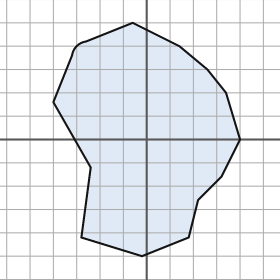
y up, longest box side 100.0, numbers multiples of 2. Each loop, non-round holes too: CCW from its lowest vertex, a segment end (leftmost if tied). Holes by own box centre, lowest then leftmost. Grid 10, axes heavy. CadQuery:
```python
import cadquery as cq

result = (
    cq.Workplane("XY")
    .moveTo(-2.0, -50.0)
    .lineTo(18.0, -42.0)
    .lineTo(22.0, -26.0)
    .lineTo(32.0, -16.0)
    .lineTo(40.0, 0.0)
    .lineTo(34.0, 20.0)
    .lineTo(26.0, 30.0)
    .lineTo(14.0, 40.0)
    .lineTo(-6.0, 50.0)
    .lineTo(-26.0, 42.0)
    .threePointArc((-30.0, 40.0), (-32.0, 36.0))
    .lineTo(-40.0, 16.0)
    .lineTo(-24.0, -12.0)
    .lineTo(-28.0, -42.0)
    .close()
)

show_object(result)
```